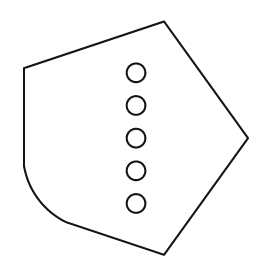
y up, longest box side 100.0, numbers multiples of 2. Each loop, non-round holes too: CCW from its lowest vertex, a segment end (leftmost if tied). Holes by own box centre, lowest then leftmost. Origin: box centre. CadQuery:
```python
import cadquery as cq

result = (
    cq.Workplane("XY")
    .moveTo(12.0, -50.0)
    .lineTo(48.0, 0.0)
    .lineTo(12.0, 50.0)
    .lineTo(-48.0, 30.0)
    .lineTo(-48.0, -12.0)
    .threePointArc((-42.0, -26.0), (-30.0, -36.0))
    .close()
    .moveTo(0.0, -28.0)
    .circle(4.0)
    .moveTo(0.0, -14.0)
    .circle(4.0)
    .moveTo(0.0, 0.0)
    .circle(4.0)
    .moveTo(0.0, 14.0)
    .circle(4.0)
    .moveTo(0.0, 28.0)
    .circle(4.0)
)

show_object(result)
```